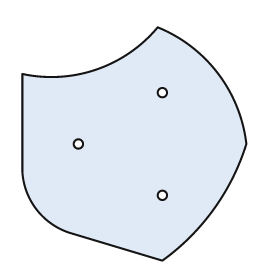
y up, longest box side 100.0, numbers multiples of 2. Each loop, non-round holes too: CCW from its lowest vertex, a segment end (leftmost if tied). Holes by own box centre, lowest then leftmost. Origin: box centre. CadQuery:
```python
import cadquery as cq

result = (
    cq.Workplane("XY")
    .moveTo(12.0, -50.0)
    .threePointArc((34.0, -28.0), (48.0, 0.0))
    .threePointArc((36.0, 30.0), (10.0, 50.0))
    .threePointArc((-16.0, 32.0), (-48.0, 30.0))
    .lineTo(-48.0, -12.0)
    .threePointArc((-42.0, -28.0), (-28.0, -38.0))
    .close()
    .moveTo(12.0, -22.0)
    .circle(2.0)
    .moveTo(-24.0, 0.0)
    .circle(2.0)
    .moveTo(12.0, 22.0)
    .circle(2.0)
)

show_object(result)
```